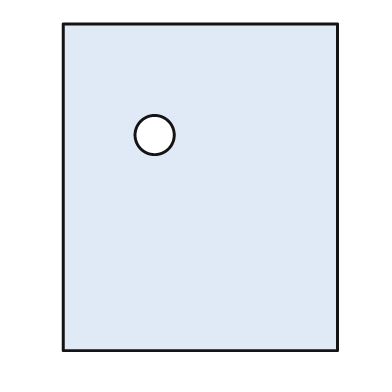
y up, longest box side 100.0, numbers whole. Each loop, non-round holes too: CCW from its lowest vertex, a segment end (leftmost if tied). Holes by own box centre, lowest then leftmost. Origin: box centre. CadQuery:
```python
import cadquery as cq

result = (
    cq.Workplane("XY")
    .moveTo(-42.0, -50.0)
    .lineTo(42.0, -50.0)
    .lineTo(42.0, 50.0)
    .lineTo(-42.0, 50.0)
    .close()
    .moveTo(-14.0, 16.0)
    .circle(6.0)
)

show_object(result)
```